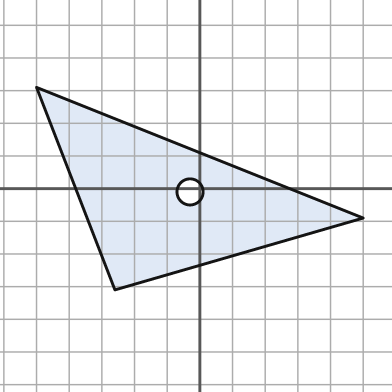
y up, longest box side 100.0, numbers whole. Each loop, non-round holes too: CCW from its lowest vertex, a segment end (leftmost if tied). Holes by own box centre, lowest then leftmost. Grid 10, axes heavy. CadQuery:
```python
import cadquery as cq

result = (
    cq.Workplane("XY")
    .moveTo(-26.0, -31.0)
    .lineTo(50.0, -9.0)
    .lineTo(-50.0, 31.0)
    .close()
    .moveTo(-3.0, -1.0)
    .circle(4.0)
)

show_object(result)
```